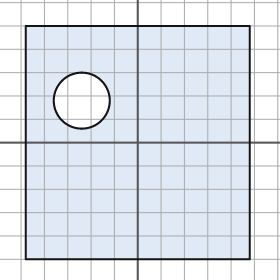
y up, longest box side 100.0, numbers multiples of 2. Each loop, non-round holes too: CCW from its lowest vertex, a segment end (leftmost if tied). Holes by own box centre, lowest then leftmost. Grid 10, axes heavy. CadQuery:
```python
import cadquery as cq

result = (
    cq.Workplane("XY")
    .moveTo(-48.0, -50.0)
    .lineTo(48.0, -50.0)
    .lineTo(48.0, 50.0)
    .lineTo(-48.0, 50.0)
    .close()
    .moveTo(-24.0, 18.0)
    .circle(12.0)
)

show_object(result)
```